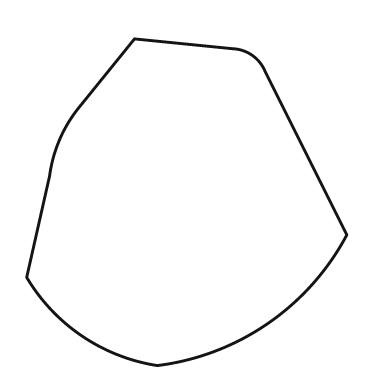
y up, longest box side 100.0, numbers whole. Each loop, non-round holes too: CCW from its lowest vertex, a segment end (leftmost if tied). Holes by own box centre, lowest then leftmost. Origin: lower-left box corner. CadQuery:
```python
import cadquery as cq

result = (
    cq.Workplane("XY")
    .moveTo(40.0, 0.0)
    .threePointArc((74.0, 13.0), (98.0, 40.0))
    .lineTo(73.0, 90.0)
    .threePointArc((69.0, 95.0), (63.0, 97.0))
    .lineTo(33.0, 100.0)
    .lineTo(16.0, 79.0)
    .threePointArc((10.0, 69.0), (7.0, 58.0))
    .lineTo(0.0, 27.0)
    .threePointArc((17.0, 9.0), (40.0, 0.0))
    .close()
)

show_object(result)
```